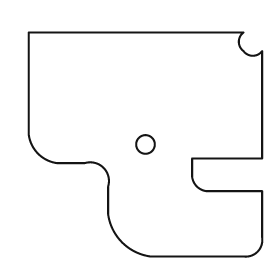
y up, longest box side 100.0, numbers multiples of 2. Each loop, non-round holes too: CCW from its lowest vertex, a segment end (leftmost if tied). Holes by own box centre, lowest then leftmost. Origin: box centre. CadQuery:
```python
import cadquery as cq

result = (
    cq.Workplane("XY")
    .moveTo(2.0, -48.0)
    .lineTo(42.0, -48.0)
    .threePointArc((48.0, -46.0), (50.0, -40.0))
    .lineTo(50.0, -20.0)
    .lineTo(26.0, -20.0)
    .threePointArc((22.0, -18.0), (20.0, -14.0))
    .lineTo(20.0, -6.0)
    .lineTo(50.0, -6.0)
    .lineTo(50.0, 40.0)
    .threePointArc((46.0, 38.0), (42.0, 40.0))
    .threePointArc((40.0, 44.0), (42.0, 48.0))
    .lineTo(-50.0, 48.0)
    .lineTo(-50.0, 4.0)
    .threePointArc((-46.0, -4.0), (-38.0, -8.0))
    .lineTo(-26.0, -8.0)
    .threePointArc((-18.0, -10.0), (-16.0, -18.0))
    .lineTo(-16.0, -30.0)
    .threePointArc((-10.0, -42.0), (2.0, -48.0))
    .close()
    .moveTo(0.0, 0.0)
    .circle(4.0)
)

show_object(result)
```